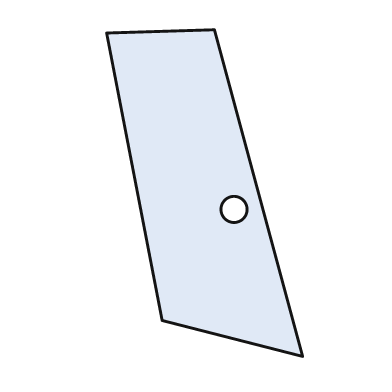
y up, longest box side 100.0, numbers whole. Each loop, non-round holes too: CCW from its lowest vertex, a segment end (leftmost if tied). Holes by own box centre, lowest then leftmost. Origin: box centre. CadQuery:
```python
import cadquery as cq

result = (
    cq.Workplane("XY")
    .moveTo(30.0, -50.0)
    .lineTo(3.0, 50.0)
    .lineTo(-30.0, 49.0)
    .lineTo(-13.0, -39.0)
    .close()
    .moveTo(9.0, -5.0)
    .circle(4.0)
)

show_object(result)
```